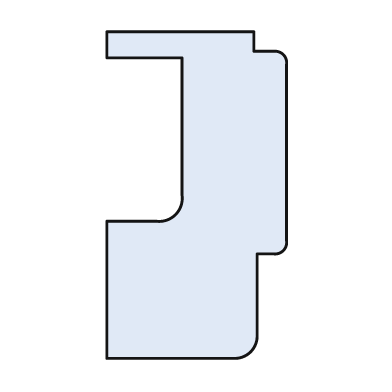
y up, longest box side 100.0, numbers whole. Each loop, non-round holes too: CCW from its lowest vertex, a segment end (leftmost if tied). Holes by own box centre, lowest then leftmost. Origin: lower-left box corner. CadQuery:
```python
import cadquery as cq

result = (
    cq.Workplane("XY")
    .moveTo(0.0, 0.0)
    .lineTo(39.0, 0.0)
    .threePointArc((44.0, 2.0), (46.0, 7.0))
    .lineTo(46.0, 32.0)
    .lineTo(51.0, 32.0)
    .threePointArc((54.0, 33.0), (55.0, 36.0))
    .lineTo(55.0, 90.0)
    .threePointArc((54.0, 93.0), (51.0, 94.0))
    .lineTo(45.0, 94.0)
    .lineTo(45.0, 100.0)
    .lineTo(0.0, 100.0)
    .lineTo(0.0, 92.0)
    .lineTo(23.0, 92.0)
    .lineTo(23.0, 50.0)
    .threePointArc((21.0, 44.0), (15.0, 42.0))
    .lineTo(0.0, 42.0)
    .close()
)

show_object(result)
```